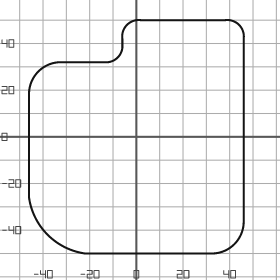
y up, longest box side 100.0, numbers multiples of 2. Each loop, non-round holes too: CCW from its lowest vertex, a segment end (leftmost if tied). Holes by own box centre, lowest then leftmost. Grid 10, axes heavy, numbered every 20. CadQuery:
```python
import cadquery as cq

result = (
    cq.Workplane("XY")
    .moveTo(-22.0, -50.0)
    .lineTo(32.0, -50.0)
    .threePointArc((42.0, -46.0), (46.0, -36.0))
    .lineTo(46.0, 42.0)
    .threePointArc((44.0, 48.0), (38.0, 50.0))
    .lineTo(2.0, 50.0)
    .threePointArc((-4.0, 48.0), (-6.0, 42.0))
    .lineTo(-6.0, 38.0)
    .threePointArc((-8.0, 34.0), (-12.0, 32.0))
    .lineTo(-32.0, 32.0)
    .threePointArc((-42.0, 28.0), (-46.0, 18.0))
    .lineTo(-46.0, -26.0)
    .threePointArc((-38.0, -42.0), (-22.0, -50.0))
    .close()
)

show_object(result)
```